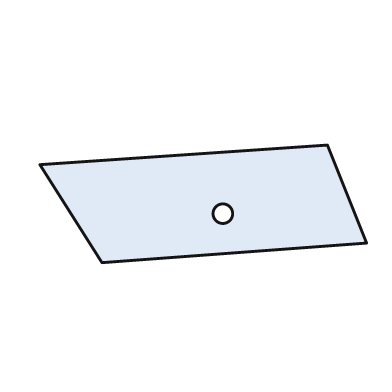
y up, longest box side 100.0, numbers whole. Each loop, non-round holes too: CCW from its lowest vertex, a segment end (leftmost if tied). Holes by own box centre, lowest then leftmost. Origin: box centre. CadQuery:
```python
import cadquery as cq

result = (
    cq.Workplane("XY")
    .moveTo(-31.0, -18.0)
    .lineTo(50.0, -12.0)
    .lineTo(38.0, 18.0)
    .lineTo(-50.0, 12.0)
    .close()
    .moveTo(6.0, -3.0)
    .circle(3.0)
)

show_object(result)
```